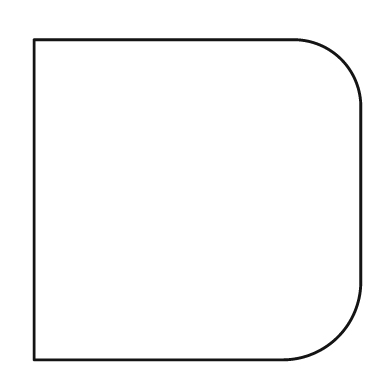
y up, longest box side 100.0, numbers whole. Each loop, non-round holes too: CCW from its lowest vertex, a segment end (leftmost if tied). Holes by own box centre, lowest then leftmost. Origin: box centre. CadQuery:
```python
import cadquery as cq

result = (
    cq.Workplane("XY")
    .moveTo(-50.0, -49.0)
    .lineTo(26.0, -49.0)
    .threePointArc((43.0, -42.0), (50.0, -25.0))
    .lineTo(50.0, 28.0)
    .threePointArc((44.0, 43.0), (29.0, 49.0))
    .lineTo(-50.0, 49.0)
    .close()
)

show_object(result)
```